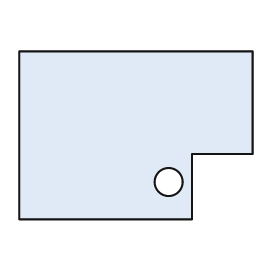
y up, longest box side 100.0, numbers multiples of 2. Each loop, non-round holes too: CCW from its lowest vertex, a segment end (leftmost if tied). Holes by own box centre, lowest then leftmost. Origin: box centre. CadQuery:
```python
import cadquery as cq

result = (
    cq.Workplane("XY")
    .moveTo(-50.0, -36.0)
    .lineTo(24.0, -36.0)
    .lineTo(24.0, -8.0)
    .lineTo(50.0, -8.0)
    .lineTo(50.0, 36.0)
    .lineTo(-50.0, 36.0)
    .close()
    .moveTo(14.0, -20.0)
    .circle(6.0)
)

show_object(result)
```